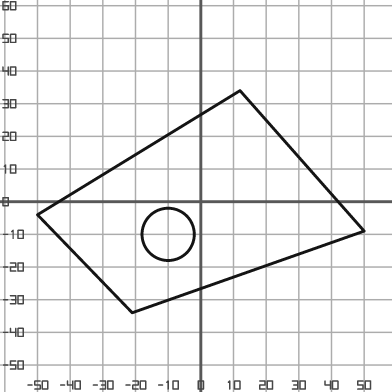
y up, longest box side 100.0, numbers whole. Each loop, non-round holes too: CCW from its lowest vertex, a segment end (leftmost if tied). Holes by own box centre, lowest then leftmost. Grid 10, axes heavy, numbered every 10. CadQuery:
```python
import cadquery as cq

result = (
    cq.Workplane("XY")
    .moveTo(-21.0, -34.0)
    .lineTo(50.0, -9.0)
    .lineTo(12.0, 34.0)
    .lineTo(-50.0, -4.0)
    .close()
    .moveTo(-10.0, -10.0)
    .circle(8.0)
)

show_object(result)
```